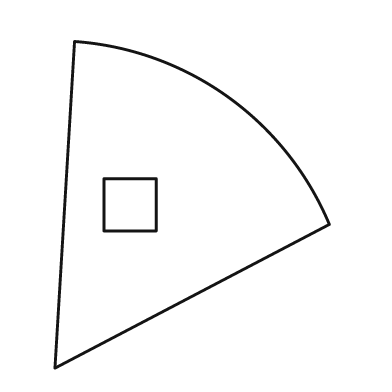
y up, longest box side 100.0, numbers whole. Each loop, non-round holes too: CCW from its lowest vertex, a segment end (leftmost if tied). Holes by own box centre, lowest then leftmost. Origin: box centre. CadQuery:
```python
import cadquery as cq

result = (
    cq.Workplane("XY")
    .moveTo(-42.0, -50.0)
    .lineTo(42.0, -6.0)
    .threePointArc((11.0, 33.0), (-36.0, 50.0))
    .close()
    .moveTo(-27.0, -8.0)
    .lineTo(-11.0, -8.0)
    .lineTo(-11.0, 8.0)
    .lineTo(-27.0, 8.0)
    .close()
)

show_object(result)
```